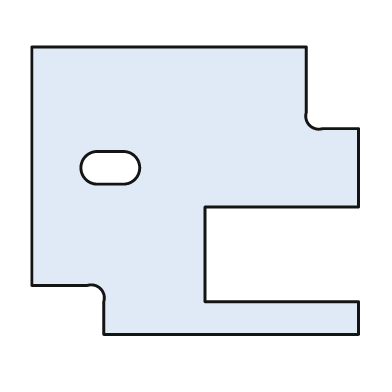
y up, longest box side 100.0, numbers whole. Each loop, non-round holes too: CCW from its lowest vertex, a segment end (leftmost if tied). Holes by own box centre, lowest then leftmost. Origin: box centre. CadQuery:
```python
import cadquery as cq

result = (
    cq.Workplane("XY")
    .moveTo(-28.0, -44.0)
    .lineTo(50.0, -44.0)
    .lineTo(50.0, -34.0)
    .lineTo(3.0, -34.0)
    .lineTo(3.0, -5.0)
    .lineTo(50.0, -5.0)
    .lineTo(50.0, 19.0)
    .lineTo(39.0, 19.0)
    .threePointArc((35.0, 20.0), (34.0, 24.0))
    .lineTo(34.0, 44.0)
    .lineTo(-50.0, 44.0)
    .lineTo(-50.0, -29.0)
    .lineTo(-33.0, -29.0)
    .threePointArc((-29.0, -30.0), (-28.0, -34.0))
    .close()
    .moveTo(-30.0, 2.0)
    .lineTo(-22.0, 2.0)
    .threePointArc((-17.0, 7.0), (-22.0, 12.0))
    .lineTo(-30.0, 12.0)
    .threePointArc((-35.0, 7.0), (-30.0, 2.0))
    .close()
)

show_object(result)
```